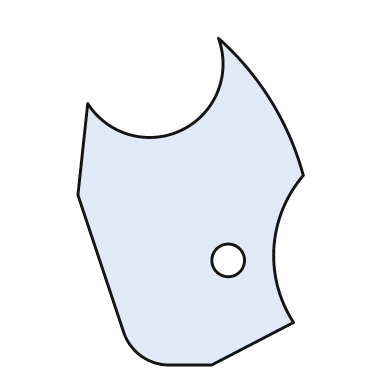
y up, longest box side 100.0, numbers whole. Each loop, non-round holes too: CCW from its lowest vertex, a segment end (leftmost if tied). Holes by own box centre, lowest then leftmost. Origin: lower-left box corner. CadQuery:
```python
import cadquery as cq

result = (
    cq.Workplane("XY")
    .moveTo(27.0, 0.0)
    .lineTo(41.0, 0.0)
    .lineTo(66.0, 13.0)
    .threePointArc((60.0, 36.0), (69.0, 58.0))
    .threePointArc((59.0, 81.0), (43.0, 100.0))
    .threePointArc((32.0, 72.0), (3.0, 80.0))
    .lineTo(0.0, 52.0)
    .lineTo(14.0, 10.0)
    .threePointArc((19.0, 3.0), (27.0, 0.0))
    .close()
    .moveTo(46.0, 32.0)
    .circle(5.0)
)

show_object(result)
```